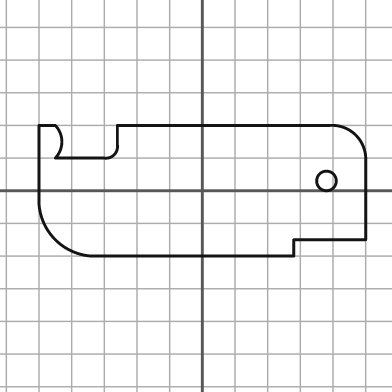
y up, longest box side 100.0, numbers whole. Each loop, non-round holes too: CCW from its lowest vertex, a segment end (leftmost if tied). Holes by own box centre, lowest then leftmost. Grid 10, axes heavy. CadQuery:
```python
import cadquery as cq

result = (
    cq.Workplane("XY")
    .moveTo(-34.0, -20.0)
    .lineTo(28.0, -20.0)
    .lineTo(28.0, -15.0)
    .lineTo(50.0, -15.0)
    .lineTo(50.0, 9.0)
    .threePointArc((47.0, 17.0), (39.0, 20.0))
    .lineTo(-26.0, 20.0)
    .lineTo(-26.0, 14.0)
    .threePointArc((-27.0, 11.0), (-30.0, 10.0))
    .lineTo(-45.0, 10.0)
    .threePointArc((-43.0, 15.0), (-45.0, 20.0))
    .lineTo(-50.0, 20.0)
    .lineTo(-50.0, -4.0)
    .threePointArc((-45.0, -15.0), (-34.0, -20.0))
    .close()
    .moveTo(38.0, 3.0)
    .circle(3.0)
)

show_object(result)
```